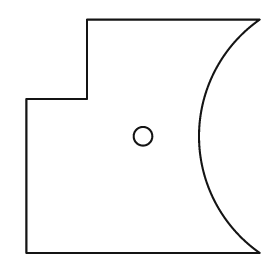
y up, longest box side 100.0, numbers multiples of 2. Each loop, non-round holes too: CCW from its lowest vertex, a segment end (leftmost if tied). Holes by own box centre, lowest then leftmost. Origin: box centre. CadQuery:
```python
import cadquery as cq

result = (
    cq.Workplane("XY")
    .moveTo(-50.0, -50.0)
    .lineTo(50.0, -50.0)
    .threePointArc((24.0, 0.0), (50.0, 50.0))
    .lineTo(-24.0, 50.0)
    .lineTo(-24.0, 16.0)
    .lineTo(-50.0, 16.0)
    .close()
    .moveTo(0.0, 0.0)
    .circle(4.0)
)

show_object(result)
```